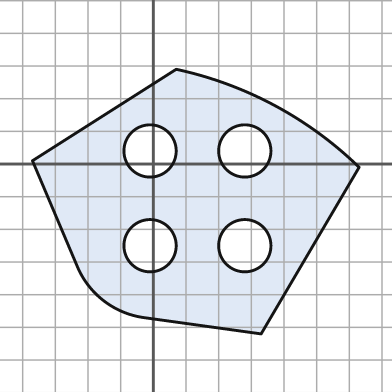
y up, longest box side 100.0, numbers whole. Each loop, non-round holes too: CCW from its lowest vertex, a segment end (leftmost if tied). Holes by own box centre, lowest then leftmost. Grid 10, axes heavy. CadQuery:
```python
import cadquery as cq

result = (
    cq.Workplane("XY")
    .moveTo(33.0, -52.0)
    .lineTo(63.0, -1.0)
    .threePointArc((37.0, 18.0), (7.0, 29.0))
    .lineTo(-37.0, 1.0)
    .lineTo(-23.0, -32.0)
    .threePointArc((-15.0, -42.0), (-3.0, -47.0))
    .close()
    .moveTo(-1.0, -25.0)
    .circle(8.0)
    .moveTo(28.0, -25.0)
    .circle(8.0)
    .moveTo(-1.0, 4.0)
    .circle(8.0)
    .moveTo(28.0, 4.0)
    .circle(8.0)
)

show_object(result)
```